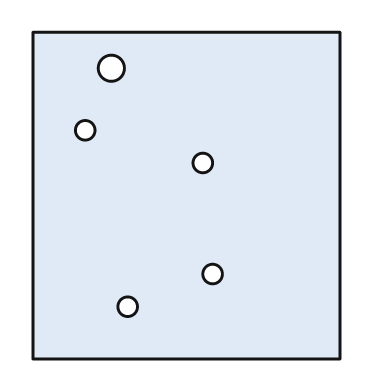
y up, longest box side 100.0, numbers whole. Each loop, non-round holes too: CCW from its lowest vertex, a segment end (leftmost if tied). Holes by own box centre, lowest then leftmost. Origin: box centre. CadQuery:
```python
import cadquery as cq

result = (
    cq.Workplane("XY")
    .moveTo(-47.0, -50.0)
    .lineTo(47.0, -50.0)
    .lineTo(47.0, 50.0)
    .lineTo(-47.0, 50.0)
    .close()
    .moveTo(-18.0, -34.0)
    .circle(3.0)
    .moveTo(8.0, -24.0)
    .circle(3.0)
    .moveTo(5.0, 10.0)
    .circle(3.0)
    .moveTo(-31.0, 20.0)
    .circle(3.0)
    .moveTo(-23.0, 39.0)
    .circle(4.0)
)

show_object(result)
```